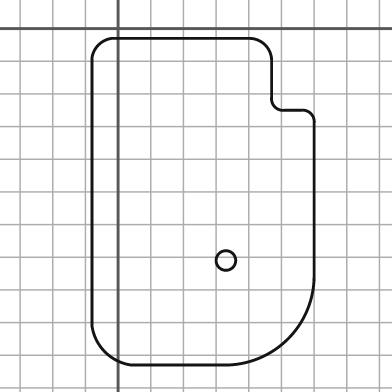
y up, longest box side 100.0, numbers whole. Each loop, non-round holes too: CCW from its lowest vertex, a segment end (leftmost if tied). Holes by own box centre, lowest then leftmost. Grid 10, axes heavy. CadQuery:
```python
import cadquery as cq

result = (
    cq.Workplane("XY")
    .moveTo(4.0, -103.0)
    .lineTo(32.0, -103.0)
    .threePointArc((52.0, -95.0), (60.0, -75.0))
    .lineTo(60.0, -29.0)
    .threePointArc((59.0, -26.0), (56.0, -25.0))
    .lineTo(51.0, -25.0)
    .threePointArc((48.0, -24.0), (47.0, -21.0))
    .lineTo(47.0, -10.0)
    .threePointArc((45.0, -5.0), (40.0, -3.0))
    .lineTo(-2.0, -3.0)
    .threePointArc((-6.0, -5.0), (-8.0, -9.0))
    .lineTo(-8.0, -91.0)
    .threePointArc((-4.0, -99.0), (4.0, -103.0))
    .close()
    .moveTo(33.0, -71.0)
    .circle(3.0)
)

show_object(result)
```